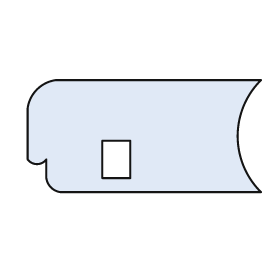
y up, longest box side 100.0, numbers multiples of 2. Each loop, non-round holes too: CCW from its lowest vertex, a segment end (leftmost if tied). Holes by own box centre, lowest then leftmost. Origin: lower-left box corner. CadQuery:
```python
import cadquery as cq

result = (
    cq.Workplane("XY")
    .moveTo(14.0, 0.0)
    .lineTo(100.0, 0.0)
    .threePointArc((90.0, 24.0), (100.0, 48.0))
    .lineTo(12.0, 48.0)
    .threePointArc((4.0, 44.0), (0.0, 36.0))
    .lineTo(0.0, 14.0)
    .threePointArc((4.0, 12.0), (8.0, 14.0))
    .lineTo(8.0, 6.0)
    .threePointArc((10.0, 2.0), (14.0, 0.0))
    .close()
    .moveTo(32.0, 6.0)
    .lineTo(44.0, 6.0)
    .lineTo(44.0, 22.0)
    .lineTo(32.0, 22.0)
    .close()
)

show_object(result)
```